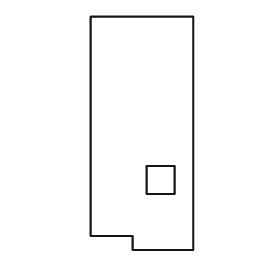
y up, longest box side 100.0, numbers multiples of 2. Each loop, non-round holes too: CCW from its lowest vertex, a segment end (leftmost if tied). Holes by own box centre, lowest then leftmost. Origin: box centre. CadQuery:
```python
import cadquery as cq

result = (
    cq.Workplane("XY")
    .moveTo(-4.0, -50.0)
    .lineTo(22.0, -50.0)
    .lineTo(22.0, 50.0)
    .lineTo(-22.0, 50.0)
    .lineTo(-22.0, -44.0)
    .lineTo(-4.0, -44.0)
    .close()
    .moveTo(2.0, -26.0)
    .lineTo(14.0, -26.0)
    .lineTo(14.0, -14.0)
    .lineTo(2.0, -14.0)
    .close()
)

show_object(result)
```